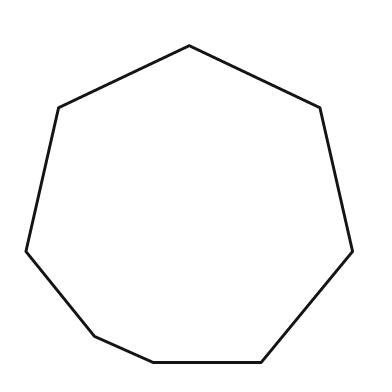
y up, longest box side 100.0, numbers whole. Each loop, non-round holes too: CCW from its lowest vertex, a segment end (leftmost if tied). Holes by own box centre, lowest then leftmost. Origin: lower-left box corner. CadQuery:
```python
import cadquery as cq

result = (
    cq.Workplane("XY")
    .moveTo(39.0, 0.0)
    .lineTo(72.0, 0.0)
    .lineTo(100.0, 34.0)
    .lineTo(90.0, 78.0)
    .lineTo(50.0, 97.0)
    .lineTo(10.0, 78.0)
    .lineTo(0.0, 34.0)
    .lineTo(21.0, 8.0)
    .close()
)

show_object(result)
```